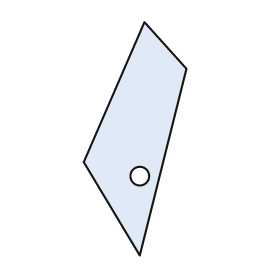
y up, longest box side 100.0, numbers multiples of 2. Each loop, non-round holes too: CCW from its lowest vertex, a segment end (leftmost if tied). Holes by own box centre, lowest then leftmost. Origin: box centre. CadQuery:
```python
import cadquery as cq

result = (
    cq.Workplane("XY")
    .moveTo(2.0, -50.0)
    .lineTo(22.0, 30.0)
    .lineTo(4.0, 50.0)
    .lineTo(-22.0, -10.0)
    .close()
    .moveTo(2.0, -16.0)
    .circle(4.0)
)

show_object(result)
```